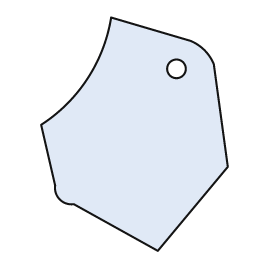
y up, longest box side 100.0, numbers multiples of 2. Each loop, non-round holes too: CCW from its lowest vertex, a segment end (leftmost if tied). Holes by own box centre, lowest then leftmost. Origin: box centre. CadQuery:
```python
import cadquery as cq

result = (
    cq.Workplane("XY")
    .moveTo(10.0, -50.0)
    .lineTo(40.0, -14.0)
    .lineTo(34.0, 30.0)
    .threePointArc((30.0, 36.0), (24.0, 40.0))
    .lineTo(-10.0, 50.0)
    .threePointArc((-20.0, 24.0), (-40.0, 4.0))
    .lineTo(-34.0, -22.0)
    .threePointArc((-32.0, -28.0), (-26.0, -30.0))
    .close()
    .moveTo(18.0, 28.0)
    .circle(4.0)
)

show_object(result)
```